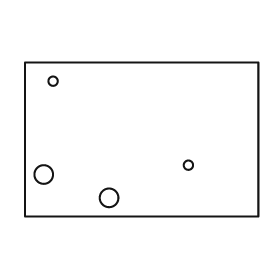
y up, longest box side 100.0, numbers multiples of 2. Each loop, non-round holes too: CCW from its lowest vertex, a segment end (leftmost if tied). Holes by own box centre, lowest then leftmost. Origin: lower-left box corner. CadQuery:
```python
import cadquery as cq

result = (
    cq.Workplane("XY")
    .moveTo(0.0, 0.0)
    .lineTo(100.0, 0.0)
    .lineTo(100.0, 66.0)
    .lineTo(0.0, 66.0)
    .close()
    .moveTo(36.0, 8.0)
    .circle(4.0)
    .moveTo(8.0, 18.0)
    .circle(4.0)
    .moveTo(70.0, 22.0)
    .circle(2.0)
    .moveTo(12.0, 58.0)
    .circle(2.0)
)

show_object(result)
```